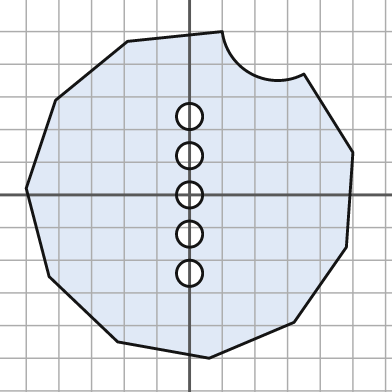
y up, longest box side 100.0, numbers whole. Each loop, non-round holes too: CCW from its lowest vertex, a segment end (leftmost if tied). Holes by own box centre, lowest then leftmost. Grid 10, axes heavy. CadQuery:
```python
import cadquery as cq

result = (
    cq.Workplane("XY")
    .moveTo(6.0, -50.0)
    .lineTo(32.0, -39.0)
    .lineTo(48.0, -16.0)
    .lineTo(50.0, 13.0)
    .lineTo(35.0, 37.0)
    .threePointArc((19.0, 37.0), (10.0, 50.0))
    .lineTo(-19.0, 47.0)
    .lineTo(-41.0, 29.0)
    .lineTo(-50.0, 2.0)
    .lineTo(-43.0, -25.0)
    .lineTo(-22.0, -45.0)
    .close()
    .moveTo(0.0, -24.0)
    .circle(4.0)
    .moveTo(0.0, -12.0)
    .circle(4.0)
    .moveTo(0.0, 0.0)
    .circle(4.0)
    .moveTo(0.0, 12.0)
    .circle(4.0)
    .moveTo(0.0, 24.0)
    .circle(4.0)
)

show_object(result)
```